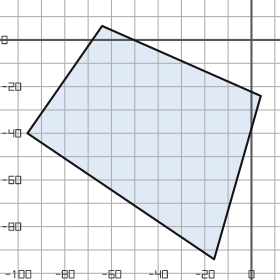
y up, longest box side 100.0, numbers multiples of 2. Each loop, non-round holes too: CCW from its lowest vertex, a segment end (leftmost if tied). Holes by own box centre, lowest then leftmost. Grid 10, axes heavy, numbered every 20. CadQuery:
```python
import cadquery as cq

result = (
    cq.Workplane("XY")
    .moveTo(-16.0, -94.0)
    .lineTo(4.0, -24.0)
    .lineTo(-64.0, 6.0)
    .lineTo(-96.0, -40.0)
    .close()
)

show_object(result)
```